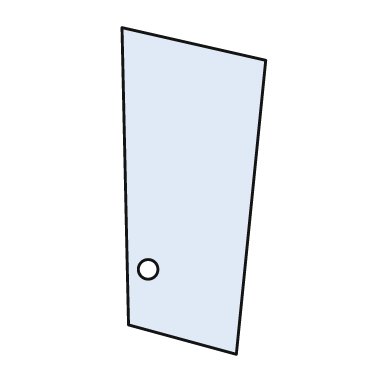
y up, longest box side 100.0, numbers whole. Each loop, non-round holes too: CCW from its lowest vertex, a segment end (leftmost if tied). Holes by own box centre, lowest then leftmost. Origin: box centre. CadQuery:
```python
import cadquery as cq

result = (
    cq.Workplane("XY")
    .moveTo(13.0, -50.0)
    .lineTo(22.0, 40.0)
    .lineTo(-22.0, 50.0)
    .lineTo(-20.0, -41.0)
    .close()
    .moveTo(-14.0, -24.0)
    .circle(3.0)
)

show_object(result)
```